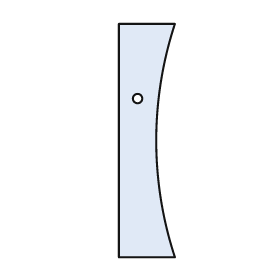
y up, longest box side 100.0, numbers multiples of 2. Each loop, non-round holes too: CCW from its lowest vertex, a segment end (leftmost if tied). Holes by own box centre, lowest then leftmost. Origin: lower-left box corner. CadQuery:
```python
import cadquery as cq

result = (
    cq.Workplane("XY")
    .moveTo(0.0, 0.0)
    .lineTo(24.0, 0.0)
    .threePointArc((16.0, 50.0), (24.0, 100.0))
    .lineTo(0.0, 100.0)
    .close()
    .moveTo(8.0, 68.0)
    .circle(2.0)
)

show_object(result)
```